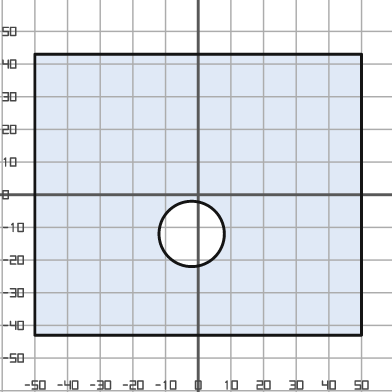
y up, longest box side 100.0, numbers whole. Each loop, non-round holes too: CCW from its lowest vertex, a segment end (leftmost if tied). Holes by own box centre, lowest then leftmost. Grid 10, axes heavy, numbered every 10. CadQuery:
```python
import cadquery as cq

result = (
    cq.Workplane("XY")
    .moveTo(-50.0, -43.0)
    .lineTo(50.0, -43.0)
    .lineTo(50.0, 43.0)
    .lineTo(-50.0, 43.0)
    .close()
    .moveTo(-2.0, -12.0)
    .circle(10.0)
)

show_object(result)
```